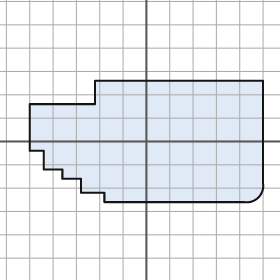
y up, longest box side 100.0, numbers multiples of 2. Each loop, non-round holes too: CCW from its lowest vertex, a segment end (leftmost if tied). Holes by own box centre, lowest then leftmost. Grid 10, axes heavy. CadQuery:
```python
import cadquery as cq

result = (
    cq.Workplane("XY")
    .moveTo(-18.0, -26.0)
    .lineTo(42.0, -26.0)
    .threePointArc((48.0, -24.0), (50.0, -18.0))
    .lineTo(50.0, 26.0)
    .lineTo(-22.0, 26.0)
    .lineTo(-22.0, 16.0)
    .lineTo(-50.0, 16.0)
    .lineTo(-50.0, -4.0)
    .lineTo(-44.0, -4.0)
    .lineTo(-44.0, -12.0)
    .lineTo(-36.0, -12.0)
    .lineTo(-36.0, -16.0)
    .lineTo(-28.0, -16.0)
    .lineTo(-28.0, -22.0)
    .lineTo(-18.0, -22.0)
    .close()
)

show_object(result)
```